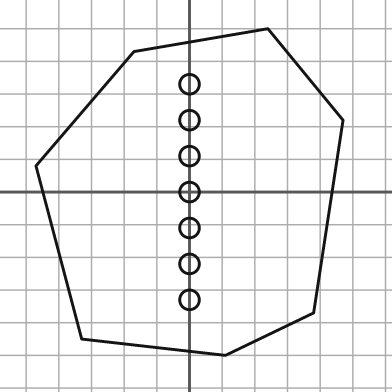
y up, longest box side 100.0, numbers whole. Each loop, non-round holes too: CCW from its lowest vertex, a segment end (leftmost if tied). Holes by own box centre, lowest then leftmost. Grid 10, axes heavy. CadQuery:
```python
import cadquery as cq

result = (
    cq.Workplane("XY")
    .moveTo(11.0, -50.0)
    .lineTo(38.0, -37.0)
    .lineTo(47.0, 22.0)
    .lineTo(24.0, 50.0)
    .lineTo(-17.0, 43.0)
    .lineTo(-47.0, 8.0)
    .lineTo(-33.0, -45.0)
    .close()
    .moveTo(0.0, -33.0)
    .circle(3.0)
    .moveTo(0.0, -22.0)
    .circle(3.0)
    .moveTo(0.0, -11.0)
    .circle(3.0)
    .moveTo(0.0, 0.0)
    .circle(3.0)
    .moveTo(0.0, 11.0)
    .circle(3.0)
    .moveTo(0.0, 22.0)
    .circle(3.0)
    .moveTo(0.0, 33.0)
    .circle(3.0)
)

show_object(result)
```